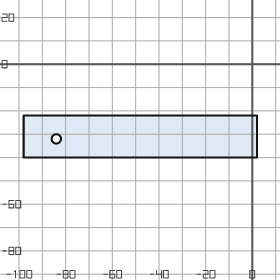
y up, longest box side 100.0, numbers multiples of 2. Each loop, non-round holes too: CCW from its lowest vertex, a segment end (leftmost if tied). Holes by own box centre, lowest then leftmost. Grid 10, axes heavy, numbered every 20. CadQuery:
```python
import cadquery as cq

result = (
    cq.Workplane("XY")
    .moveTo(-98.0, -40.0)
    .lineTo(2.0, -40.0)
    .lineTo(2.0, -22.0)
    .lineTo(-98.0, -22.0)
    .close()
    .moveTo(-84.0, -32.0)
    .circle(2.0)
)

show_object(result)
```